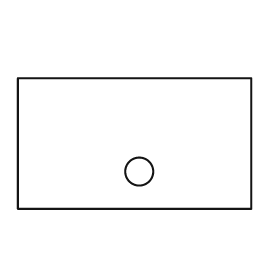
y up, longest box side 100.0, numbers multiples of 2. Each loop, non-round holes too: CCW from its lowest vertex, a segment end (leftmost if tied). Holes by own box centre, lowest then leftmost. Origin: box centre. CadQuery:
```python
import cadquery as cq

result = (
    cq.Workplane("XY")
    .moveTo(-50.0, -28.0)
    .lineTo(50.0, -28.0)
    .lineTo(50.0, 28.0)
    .lineTo(-50.0, 28.0)
    .close()
    .moveTo(2.0, -12.0)
    .circle(6.0)
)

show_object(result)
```